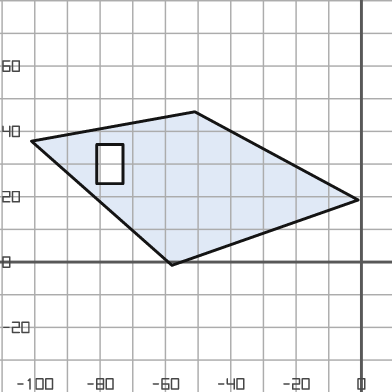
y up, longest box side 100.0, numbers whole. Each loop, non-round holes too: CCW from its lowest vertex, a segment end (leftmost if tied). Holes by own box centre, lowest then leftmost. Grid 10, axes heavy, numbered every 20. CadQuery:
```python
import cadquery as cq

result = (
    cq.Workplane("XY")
    .moveTo(-58.0, -1.0)
    .lineTo(-1.0, 19.0)
    .lineTo(-51.0, 46.0)
    .lineTo(-101.0, 37.0)
    .close()
    .moveTo(-81.0, 24.0)
    .lineTo(-73.0, 24.0)
    .lineTo(-73.0, 36.0)
    .lineTo(-81.0, 36.0)
    .close()
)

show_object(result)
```